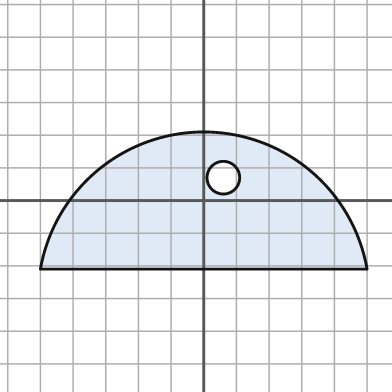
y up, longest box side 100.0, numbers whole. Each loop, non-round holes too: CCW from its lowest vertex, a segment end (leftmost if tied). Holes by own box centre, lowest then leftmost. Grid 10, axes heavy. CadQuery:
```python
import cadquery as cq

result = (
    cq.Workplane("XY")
    .moveTo(-50.0, -21.0)
    .lineTo(50.0, -21.0)
    .threePointArc((0.0, 21.0), (-50.0, -21.0))
    .close()
    .moveTo(6.0, 7.0)
    .circle(5.0)
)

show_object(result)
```